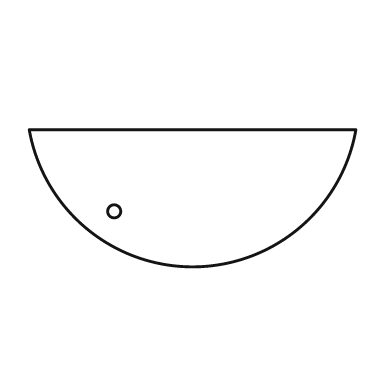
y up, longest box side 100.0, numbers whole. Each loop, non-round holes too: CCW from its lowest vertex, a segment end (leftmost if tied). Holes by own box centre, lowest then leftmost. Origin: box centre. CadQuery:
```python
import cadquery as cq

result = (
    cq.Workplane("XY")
    .moveTo(-50.0, 21.0)
    .threePointArc((0.0, -21.0), (50.0, 21.0))
    .close()
    .moveTo(-24.0, -4.0)
    .circle(2.0)
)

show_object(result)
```